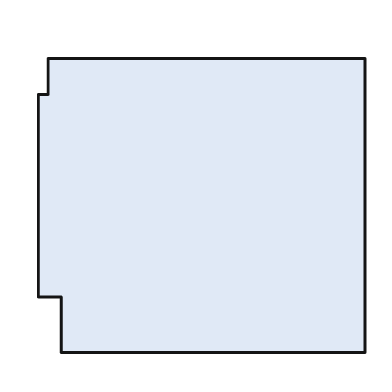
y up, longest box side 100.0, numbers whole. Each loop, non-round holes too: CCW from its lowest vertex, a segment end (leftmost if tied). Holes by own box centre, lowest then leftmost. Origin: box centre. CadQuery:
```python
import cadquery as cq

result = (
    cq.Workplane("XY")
    .moveTo(-43.0, -45.0)
    .lineTo(50.0, -45.0)
    .lineTo(50.0, 45.0)
    .lineTo(-47.0, 45.0)
    .lineTo(-47.0, 34.0)
    .lineTo(-50.0, 34.0)
    .lineTo(-50.0, -28.0)
    .lineTo(-43.0, -28.0)
    .close()
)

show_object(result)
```